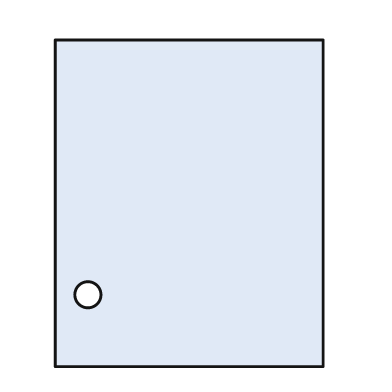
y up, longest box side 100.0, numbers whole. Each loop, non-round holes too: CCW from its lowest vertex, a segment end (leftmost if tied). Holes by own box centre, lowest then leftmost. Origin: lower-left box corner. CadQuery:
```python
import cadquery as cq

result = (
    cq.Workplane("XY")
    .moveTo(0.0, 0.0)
    .lineTo(82.0, 0.0)
    .lineTo(82.0, 100.0)
    .lineTo(0.0, 100.0)
    .close()
    .moveTo(10.0, 22.0)
    .circle(4.0)
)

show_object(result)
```